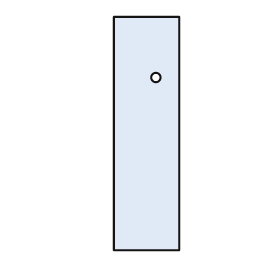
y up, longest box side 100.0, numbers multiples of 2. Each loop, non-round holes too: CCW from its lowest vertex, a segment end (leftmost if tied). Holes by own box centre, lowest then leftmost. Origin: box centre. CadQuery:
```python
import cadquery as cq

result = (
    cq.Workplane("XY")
    .moveTo(-14.0, -50.0)
    .lineTo(14.0, -50.0)
    .lineTo(14.0, 50.0)
    .lineTo(-14.0, 50.0)
    .close()
    .moveTo(4.0, 24.0)
    .circle(2.0)
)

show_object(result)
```